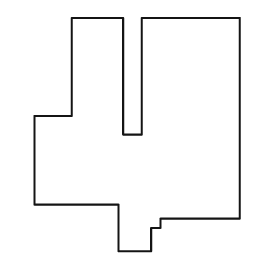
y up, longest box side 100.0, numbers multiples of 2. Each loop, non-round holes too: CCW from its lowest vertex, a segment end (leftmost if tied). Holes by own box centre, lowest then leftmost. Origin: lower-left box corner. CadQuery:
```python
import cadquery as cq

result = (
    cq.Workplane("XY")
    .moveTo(36.0, 0.0)
    .lineTo(50.0, 0.0)
    .lineTo(50.0, 10.0)
    .lineTo(54.0, 10.0)
    .lineTo(54.0, 14.0)
    .lineTo(88.0, 14.0)
    .lineTo(88.0, 100.0)
    .lineTo(46.0, 100.0)
    .lineTo(46.0, 50.0)
    .lineTo(38.0, 50.0)
    .lineTo(38.0, 100.0)
    .lineTo(16.0, 100.0)
    .lineTo(16.0, 58.0)
    .lineTo(0.0, 58.0)
    .lineTo(0.0, 20.0)
    .lineTo(36.0, 20.0)
    .close()
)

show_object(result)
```